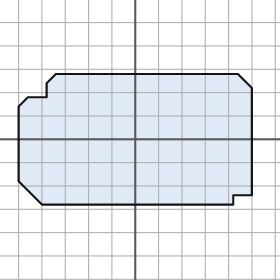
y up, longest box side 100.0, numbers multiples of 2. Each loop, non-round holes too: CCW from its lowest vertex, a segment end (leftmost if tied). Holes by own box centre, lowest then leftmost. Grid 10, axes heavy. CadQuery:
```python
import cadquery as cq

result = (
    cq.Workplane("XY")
    .moveTo(-40.0, -28.0)
    .lineTo(42.0, -28.0)
    .lineTo(42.0, -24.0)
    .lineTo(50.0, -24.0)
    .lineTo(50.0, 22.0)
    .lineTo(44.0, 28.0)
    .lineTo(-34.0, 28.0)
    .lineTo(-38.0, 24.0)
    .lineTo(-38.0, 18.0)
    .lineTo(-46.0, 18.0)
    .lineTo(-50.0, 14.0)
    .lineTo(-50.0, -18.0)
    .close()
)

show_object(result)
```